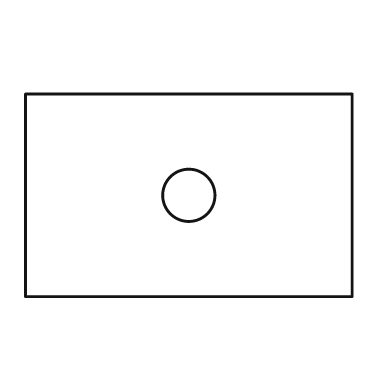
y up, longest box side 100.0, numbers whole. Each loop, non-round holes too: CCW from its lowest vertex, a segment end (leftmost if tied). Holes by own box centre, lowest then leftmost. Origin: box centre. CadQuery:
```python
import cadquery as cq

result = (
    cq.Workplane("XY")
    .moveTo(-50.0, -31.0)
    .lineTo(50.0, -31.0)
    .lineTo(50.0, 31.0)
    .lineTo(-50.0, 31.0)
    .close()
    .moveTo(0.0, 0.0)
    .circle(8.0)
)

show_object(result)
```